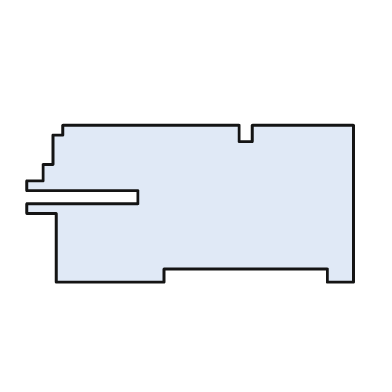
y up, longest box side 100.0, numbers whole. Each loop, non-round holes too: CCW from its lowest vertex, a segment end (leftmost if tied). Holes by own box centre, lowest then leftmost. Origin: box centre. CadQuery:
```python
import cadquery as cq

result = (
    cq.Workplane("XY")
    .moveTo(-41.0, -24.0)
    .lineTo(-8.0, -24.0)
    .lineTo(-8.0, -20.0)
    .lineTo(42.0, -20.0)
    .lineTo(42.0, -24.0)
    .lineTo(50.0, -24.0)
    .lineTo(50.0, 24.0)
    .lineTo(19.0, 24.0)
    .lineTo(19.0, 19.0)
    .lineTo(15.0, 19.0)
    .lineTo(15.0, 24.0)
    .lineTo(-39.0, 24.0)
    .lineTo(-39.0, 21.0)
    .lineTo(-42.0, 21.0)
    .lineTo(-42.0, 12.0)
    .lineTo(-45.0, 12.0)
    .lineTo(-45.0, 7.0)
    .lineTo(-50.0, 7.0)
    .lineTo(-50.0, 4.0)
    .lineTo(-16.0, 4.0)
    .lineTo(-16.0, 0.0)
    .lineTo(-50.0, 0.0)
    .lineTo(-50.0, -3.0)
    .lineTo(-41.0, -3.0)
    .close()
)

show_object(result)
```